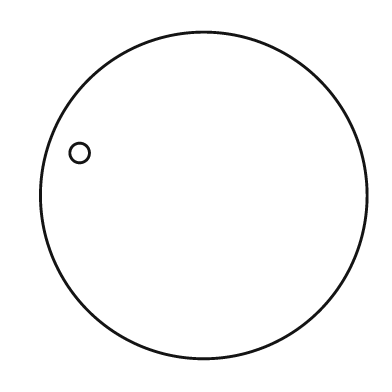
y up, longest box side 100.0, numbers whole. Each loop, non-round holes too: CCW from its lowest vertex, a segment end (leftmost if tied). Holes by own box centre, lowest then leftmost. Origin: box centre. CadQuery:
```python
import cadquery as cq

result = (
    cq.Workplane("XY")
    .moveTo(0.0, 0.0)
    .circle(50.0)
    .moveTo(-38.0, 13.0)
    .circle(3.0)
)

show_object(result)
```